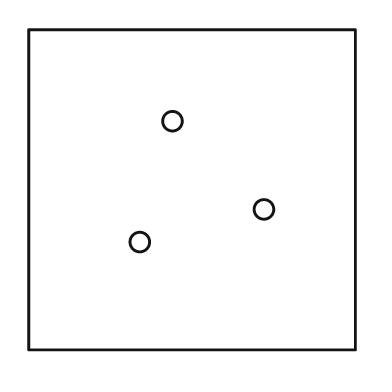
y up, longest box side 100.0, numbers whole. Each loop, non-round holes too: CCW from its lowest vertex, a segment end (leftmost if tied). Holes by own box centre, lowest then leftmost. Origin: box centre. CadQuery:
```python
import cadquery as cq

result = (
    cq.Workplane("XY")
    .moveTo(-50.0, -49.0)
    .lineTo(50.0, -49.0)
    .lineTo(50.0, 49.0)
    .lineTo(-50.0, 49.0)
    .close()
    .moveTo(-16.0, -16.0)
    .circle(3.0)
    .moveTo(22.0, -6.0)
    .circle(3.0)
    .moveTo(-6.0, 21.0)
    .circle(3.0)
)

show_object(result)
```